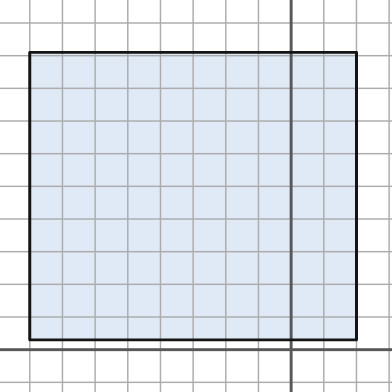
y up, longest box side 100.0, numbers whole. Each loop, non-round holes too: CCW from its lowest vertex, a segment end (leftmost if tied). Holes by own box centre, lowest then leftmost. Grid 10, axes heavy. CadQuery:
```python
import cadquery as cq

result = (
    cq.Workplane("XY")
    .moveTo(-80.0, 3.0)
    .lineTo(20.0, 3.0)
    .lineTo(20.0, 91.0)
    .lineTo(-80.0, 91.0)
    .close()
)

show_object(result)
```